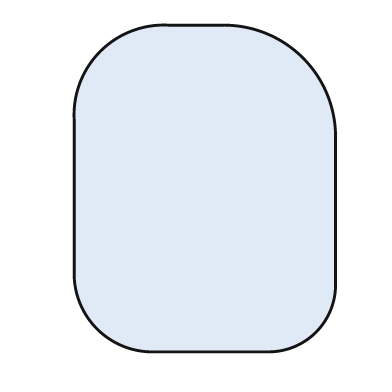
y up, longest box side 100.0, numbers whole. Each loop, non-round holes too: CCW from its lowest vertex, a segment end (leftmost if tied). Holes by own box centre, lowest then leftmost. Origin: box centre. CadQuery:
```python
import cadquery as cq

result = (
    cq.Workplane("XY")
    .moveTo(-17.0, -50.0)
    .lineTo(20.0, -50.0)
    .threePointArc((34.0, -44.0), (40.0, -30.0))
    .lineTo(40.0, 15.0)
    .threePointArc((30.0, 40.0), (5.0, 50.0))
    .lineTo(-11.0, 50.0)
    .threePointArc((-32.0, 42.0), (-40.0, 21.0))
    .lineTo(-40.0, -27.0)
    .threePointArc((-33.0, -43.0), (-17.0, -50.0))
    .close()
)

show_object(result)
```